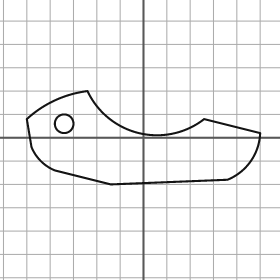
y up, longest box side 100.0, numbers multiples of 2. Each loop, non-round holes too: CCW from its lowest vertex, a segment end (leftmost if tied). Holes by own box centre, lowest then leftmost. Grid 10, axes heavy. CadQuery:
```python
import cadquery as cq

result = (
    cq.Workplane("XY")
    .moveTo(-14.0, -20.0)
    .lineTo(36.0, -18.0)
    .threePointArc((46.0, -10.0), (50.0, 2.0))
    .lineTo(26.0, 8.0)
    .threePointArc((-2.0, 2.0), (-24.0, 20.0))
    .threePointArc((-38.0, 16.0), (-50.0, 8.0))
    .lineTo(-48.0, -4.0)
    .threePointArc((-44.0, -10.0), (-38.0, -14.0))
    .close()
    .moveTo(-34.0, 6.0)
    .circle(4.0)
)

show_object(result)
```